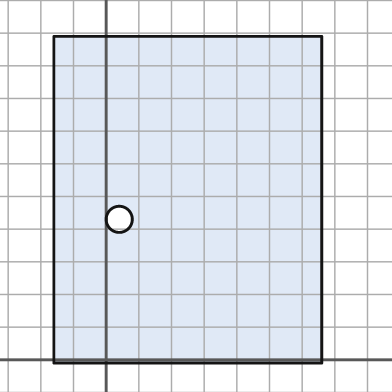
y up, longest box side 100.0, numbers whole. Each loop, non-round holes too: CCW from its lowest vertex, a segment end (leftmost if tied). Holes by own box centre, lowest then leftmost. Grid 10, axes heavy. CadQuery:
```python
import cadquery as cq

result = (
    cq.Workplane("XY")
    .moveTo(-16.0, -1.0)
    .lineTo(66.0, -1.0)
    .lineTo(66.0, 99.0)
    .lineTo(-16.0, 99.0)
    .close()
    .moveTo(4.0, 43.0)
    .circle(4.0)
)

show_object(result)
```